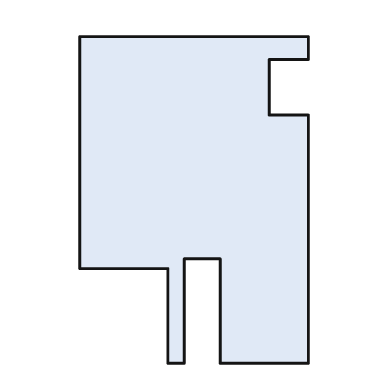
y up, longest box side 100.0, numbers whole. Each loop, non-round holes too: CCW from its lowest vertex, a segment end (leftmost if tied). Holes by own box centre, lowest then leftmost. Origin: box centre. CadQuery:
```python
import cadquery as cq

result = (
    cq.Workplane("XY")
    .moveTo(-8.0, -50.0)
    .lineTo(-3.0, -50.0)
    .lineTo(-3.0, -18.0)
    .lineTo(8.0, -18.0)
    .lineTo(8.0, -50.0)
    .lineTo(35.0, -50.0)
    .lineTo(35.0, 26.0)
    .lineTo(23.0, 26.0)
    .lineTo(23.0, 43.0)
    .lineTo(35.0, 43.0)
    .lineTo(35.0, 50.0)
    .lineTo(-35.0, 50.0)
    .lineTo(-35.0, -21.0)
    .lineTo(-8.0, -21.0)
    .close()
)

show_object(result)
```